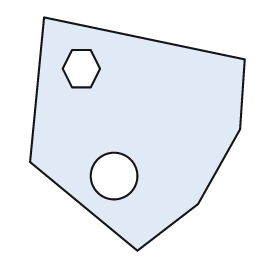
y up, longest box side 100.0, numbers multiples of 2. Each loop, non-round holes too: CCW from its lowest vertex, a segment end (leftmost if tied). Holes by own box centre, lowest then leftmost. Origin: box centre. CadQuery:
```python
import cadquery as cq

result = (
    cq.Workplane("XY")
    .moveTo(0.0, -50.0)
    .lineTo(26.0, -30.0)
    .lineTo(44.0, 2.0)
    .lineTo(46.0, 32.0)
    .lineTo(-40.0, 50.0)
    .lineTo(-46.0, -12.0)
    .close()
    .moveTo(-10.0, -18.0)
    .circle(10.0)
    .moveTo(-28.0, 20.0)
    .lineTo(-20.0, 20.0)
    .lineTo(-16.0, 28.0)
    .lineTo(-20.0, 36.0)
    .lineTo(-28.0, 36.0)
    .lineTo(-32.0, 28.0)
    .close()
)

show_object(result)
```